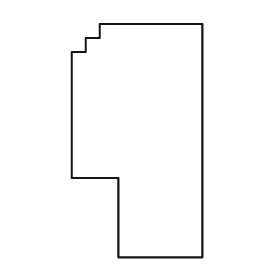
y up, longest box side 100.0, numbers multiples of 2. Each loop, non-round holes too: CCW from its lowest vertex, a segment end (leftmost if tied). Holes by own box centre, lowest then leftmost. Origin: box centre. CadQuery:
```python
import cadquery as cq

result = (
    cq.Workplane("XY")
    .moveTo(-8.0, -50.0)
    .lineTo(28.0, -50.0)
    .lineTo(28.0, 50.0)
    .lineTo(-16.0, 50.0)
    .lineTo(-16.0, 44.0)
    .lineTo(-22.0, 44.0)
    .lineTo(-22.0, 38.0)
    .lineTo(-28.0, 38.0)
    .lineTo(-28.0, -16.0)
    .lineTo(-8.0, -16.0)
    .close()
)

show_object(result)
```